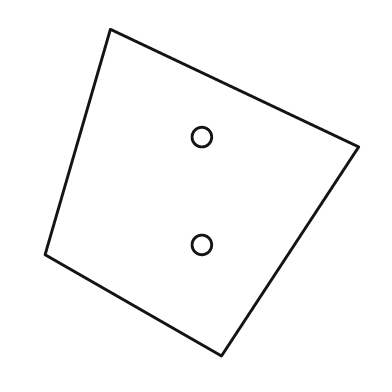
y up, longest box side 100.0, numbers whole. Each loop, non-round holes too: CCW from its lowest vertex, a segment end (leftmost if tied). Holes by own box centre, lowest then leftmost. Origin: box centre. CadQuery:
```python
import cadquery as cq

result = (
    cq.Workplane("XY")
    .moveTo(6.0, -50.0)
    .lineTo(48.0, 14.0)
    .lineTo(-28.0, 50.0)
    .lineTo(-48.0, -19.0)
    .close()
    .moveTo(0.0, -16.0)
    .circle(3.0)
    .moveTo(0.0, 17.0)
    .circle(3.0)
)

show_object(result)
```